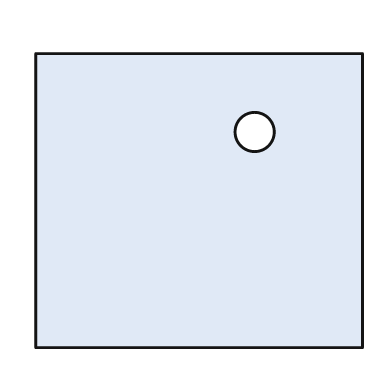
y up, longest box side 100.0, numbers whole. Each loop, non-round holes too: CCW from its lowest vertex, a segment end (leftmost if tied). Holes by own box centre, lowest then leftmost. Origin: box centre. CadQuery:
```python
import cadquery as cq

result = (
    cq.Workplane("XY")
    .moveTo(-50.0, -45.0)
    .lineTo(50.0, -45.0)
    .lineTo(50.0, 45.0)
    .lineTo(-50.0, 45.0)
    .close()
    .moveTo(17.0, 21.0)
    .circle(6.0)
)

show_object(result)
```